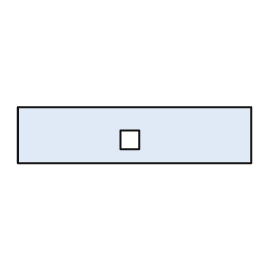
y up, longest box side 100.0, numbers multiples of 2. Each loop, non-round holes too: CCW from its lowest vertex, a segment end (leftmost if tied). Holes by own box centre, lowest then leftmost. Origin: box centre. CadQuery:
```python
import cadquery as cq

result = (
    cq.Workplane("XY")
    .moveTo(-50.0, -12.0)
    .lineTo(50.0, -12.0)
    .lineTo(50.0, 12.0)
    .lineTo(-50.0, 12.0)
    .close()
    .moveTo(-6.0, -6.0)
    .lineTo(2.0, -6.0)
    .lineTo(2.0, 2.0)
    .lineTo(-6.0, 2.0)
    .close()
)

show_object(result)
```